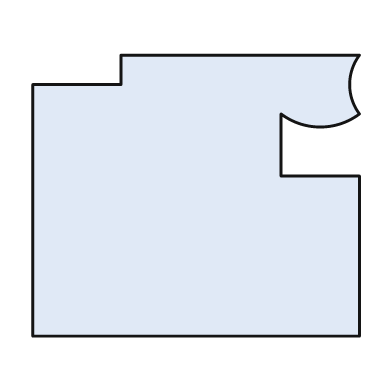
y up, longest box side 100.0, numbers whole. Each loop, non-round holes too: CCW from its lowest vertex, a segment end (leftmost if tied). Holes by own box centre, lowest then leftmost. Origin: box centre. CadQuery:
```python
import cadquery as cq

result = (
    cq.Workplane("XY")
    .moveTo(-50.0, -43.0)
    .lineTo(50.0, -43.0)
    .lineTo(50.0, 6.0)
    .lineTo(26.0, 6.0)
    .lineTo(26.0, 25.0)
    .threePointArc((38.0, 21.0), (50.0, 25.0))
    .threePointArc((47.0, 34.0), (50.0, 43.0))
    .lineTo(-23.0, 43.0)
    .lineTo(-23.0, 34.0)
    .lineTo(-50.0, 34.0)
    .close()
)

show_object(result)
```